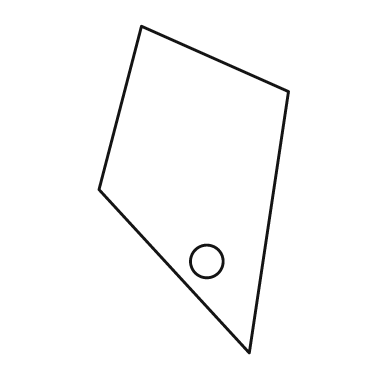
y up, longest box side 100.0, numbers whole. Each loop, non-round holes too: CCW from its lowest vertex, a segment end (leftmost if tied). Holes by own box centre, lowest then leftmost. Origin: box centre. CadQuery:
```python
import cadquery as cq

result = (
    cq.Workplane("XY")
    .moveTo(17.0, -50.0)
    .lineTo(29.0, 30.0)
    .lineTo(-16.0, 50.0)
    .lineTo(-29.0, 0.0)
    .close()
    .moveTo(4.0, -22.0)
    .circle(5.0)
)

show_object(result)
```